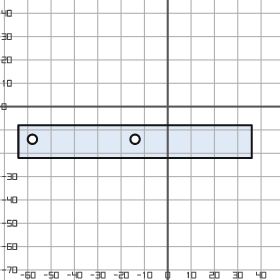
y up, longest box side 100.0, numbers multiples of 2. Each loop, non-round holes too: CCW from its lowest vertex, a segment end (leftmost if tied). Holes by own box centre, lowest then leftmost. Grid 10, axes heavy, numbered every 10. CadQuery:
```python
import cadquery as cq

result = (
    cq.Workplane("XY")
    .moveTo(-64.0, -22.0)
    .lineTo(36.0, -22.0)
    .lineTo(36.0, -8.0)
    .lineTo(-64.0, -8.0)
    .close()
    .moveTo(-58.0, -14.0)
    .circle(2.0)
    .moveTo(-14.0, -14.0)
    .circle(2.0)
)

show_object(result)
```